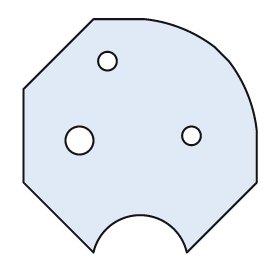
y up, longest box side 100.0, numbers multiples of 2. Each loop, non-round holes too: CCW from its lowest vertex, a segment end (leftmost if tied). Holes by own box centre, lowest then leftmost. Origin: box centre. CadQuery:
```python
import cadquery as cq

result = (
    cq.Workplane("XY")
    .moveTo(-20.0, -50.0)
    .threePointArc((0.0, -34.0), (20.0, -50.0))
    .lineTo(50.0, -20.0)
    .lineTo(50.0, 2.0)
    .threePointArc((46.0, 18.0), (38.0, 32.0))
    .lineTo(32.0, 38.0)
    .threePointArc((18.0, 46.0), (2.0, 50.0))
    .lineTo(-20.0, 50.0)
    .lineTo(-50.0, 20.0)
    .lineTo(-50.0, -20.0)
    .close()
    .moveTo(-26.0, -2.0)
    .circle(6.0)
    .moveTo(22.0, 0.0)
    .circle(4.0)
    .moveTo(-14.0, 32.0)
    .circle(4.0)
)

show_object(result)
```